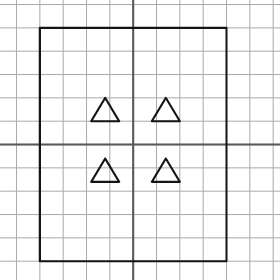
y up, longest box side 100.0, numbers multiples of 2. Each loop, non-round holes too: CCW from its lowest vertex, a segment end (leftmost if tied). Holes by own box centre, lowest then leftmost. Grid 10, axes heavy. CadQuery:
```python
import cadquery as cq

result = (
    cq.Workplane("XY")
    .moveTo(-40.0, -50.0)
    .lineTo(40.0, -50.0)
    .lineTo(40.0, 50.0)
    .lineTo(-40.0, 50.0)
    .close()
    .moveTo(-18.0, -16.0)
    .lineTo(-6.0, -16.0)
    .lineTo(-12.0, -6.0)
    .close()
    .moveTo(8.0, -16.0)
    .lineTo(20.0, -16.0)
    .lineTo(14.0, -6.0)
    .close()
    .moveTo(-18.0, 10.0)
    .lineTo(-6.0, 10.0)
    .lineTo(-12.0, 20.0)
    .close()
    .moveTo(8.0, 10.0)
    .lineTo(20.0, 10.0)
    .lineTo(14.0, 20.0)
    .close()
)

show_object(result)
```